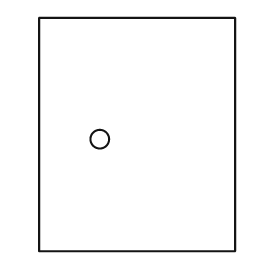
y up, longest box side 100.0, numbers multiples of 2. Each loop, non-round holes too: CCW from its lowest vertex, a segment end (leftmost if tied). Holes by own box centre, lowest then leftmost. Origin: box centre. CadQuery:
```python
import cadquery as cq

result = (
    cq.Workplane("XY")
    .moveTo(-42.0, -50.0)
    .lineTo(42.0, -50.0)
    .lineTo(42.0, 50.0)
    .lineTo(-42.0, 50.0)
    .close()
    .moveTo(-16.0, -2.0)
    .circle(4.0)
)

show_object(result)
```